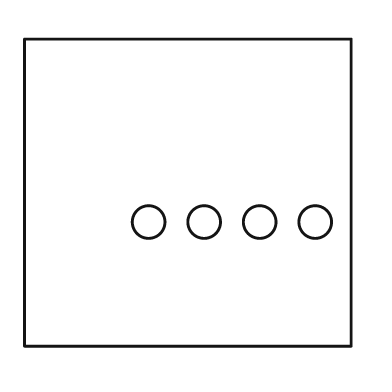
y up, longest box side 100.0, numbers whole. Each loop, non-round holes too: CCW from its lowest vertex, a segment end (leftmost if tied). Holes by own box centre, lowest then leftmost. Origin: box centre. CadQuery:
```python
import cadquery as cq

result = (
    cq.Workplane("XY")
    .moveTo(-50.0, -47.0)
    .lineTo(50.0, -47.0)
    .lineTo(50.0, 47.0)
    .lineTo(-50.0, 47.0)
    .close()
    .moveTo(-12.0, -9.0)
    .circle(5.0)
    .moveTo(5.0, -9.0)
    .circle(5.0)
    .moveTo(22.0, -9.0)
    .circle(5.0)
    .moveTo(39.0, -9.0)
    .circle(5.0)
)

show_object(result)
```